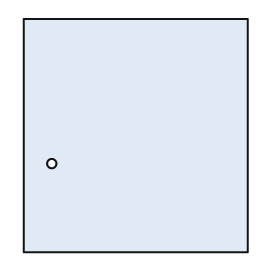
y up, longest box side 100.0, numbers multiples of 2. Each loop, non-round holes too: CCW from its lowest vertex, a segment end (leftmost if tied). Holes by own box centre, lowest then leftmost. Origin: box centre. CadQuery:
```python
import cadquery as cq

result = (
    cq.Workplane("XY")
    .moveTo(-48.0, -50.0)
    .lineTo(48.0, -50.0)
    .lineTo(48.0, 50.0)
    .lineTo(-48.0, 50.0)
    .close()
    .moveTo(-36.0, -12.0)
    .circle(2.0)
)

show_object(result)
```